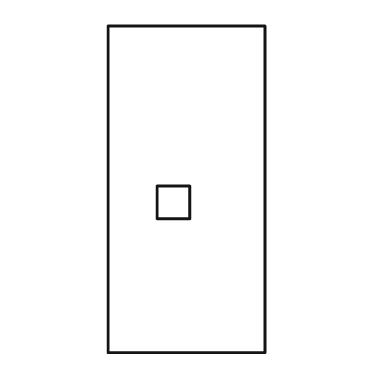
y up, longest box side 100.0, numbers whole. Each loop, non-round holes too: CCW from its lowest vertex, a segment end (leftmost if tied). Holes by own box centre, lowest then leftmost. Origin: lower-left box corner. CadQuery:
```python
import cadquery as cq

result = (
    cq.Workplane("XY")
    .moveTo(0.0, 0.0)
    .lineTo(48.0, 0.0)
    .lineTo(48.0, 100.0)
    .lineTo(0.0, 100.0)
    .close()
    .moveTo(15.0, 41.0)
    .lineTo(25.0, 41.0)
    .lineTo(25.0, 51.0)
    .lineTo(15.0, 51.0)
    .close()
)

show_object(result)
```